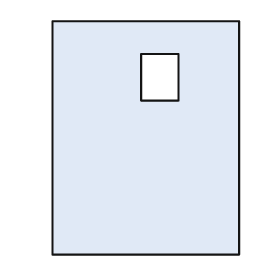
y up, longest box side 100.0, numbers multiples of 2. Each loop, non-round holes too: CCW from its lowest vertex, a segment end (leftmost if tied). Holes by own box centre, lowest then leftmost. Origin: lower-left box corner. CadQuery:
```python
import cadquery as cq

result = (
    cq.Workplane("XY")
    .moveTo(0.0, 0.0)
    .lineTo(80.0, 0.0)
    .lineTo(80.0, 100.0)
    .lineTo(0.0, 100.0)
    .close()
    .moveTo(38.0, 66.0)
    .lineTo(54.0, 66.0)
    .lineTo(54.0, 86.0)
    .lineTo(38.0, 86.0)
    .close()
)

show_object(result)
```